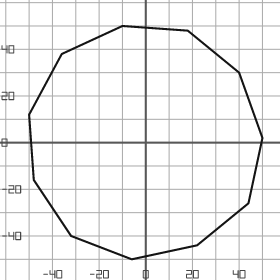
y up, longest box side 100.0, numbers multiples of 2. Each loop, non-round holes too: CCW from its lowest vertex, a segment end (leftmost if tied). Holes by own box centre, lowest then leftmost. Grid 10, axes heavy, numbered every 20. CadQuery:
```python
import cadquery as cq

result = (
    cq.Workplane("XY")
    .moveTo(-6.0, -50.0)
    .lineTo(22.0, -44.0)
    .lineTo(44.0, -26.0)
    .lineTo(50.0, 2.0)
    .lineTo(40.0, 30.0)
    .lineTo(18.0, 48.0)
    .lineTo(-10.0, 50.0)
    .lineTo(-36.0, 38.0)
    .lineTo(-50.0, 12.0)
    .lineTo(-48.0, -16.0)
    .lineTo(-32.0, -40.0)
    .close()
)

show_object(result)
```